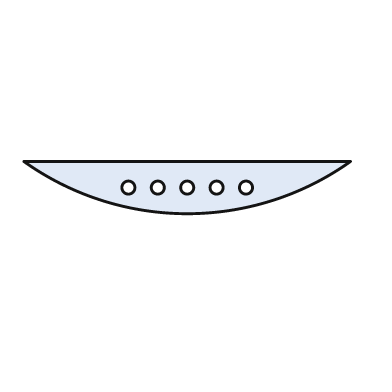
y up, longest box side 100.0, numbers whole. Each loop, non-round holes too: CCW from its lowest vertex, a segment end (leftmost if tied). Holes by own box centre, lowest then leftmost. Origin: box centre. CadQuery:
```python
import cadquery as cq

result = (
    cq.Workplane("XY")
    .moveTo(-50.0, 8.0)
    .threePointArc((0.0, -8.0), (50.0, 8.0))
    .close()
    .moveTo(-18.0, 0.0)
    .circle(2.0)
    .moveTo(-9.0, 0.0)
    .circle(2.0)
    .moveTo(0.0, 0.0)
    .circle(2.0)
    .moveTo(9.0, 0.0)
    .circle(2.0)
    .moveTo(18.0, 0.0)
    .circle(2.0)
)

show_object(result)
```